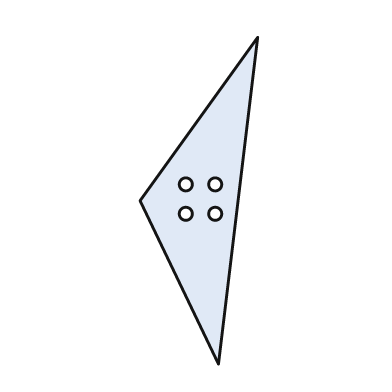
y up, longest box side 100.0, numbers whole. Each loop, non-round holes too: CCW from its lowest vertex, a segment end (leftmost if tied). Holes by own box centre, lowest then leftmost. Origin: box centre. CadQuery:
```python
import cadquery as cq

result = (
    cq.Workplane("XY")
    .moveTo(6.0, -50.0)
    .lineTo(18.0, 50.0)
    .lineTo(-18.0, 0.0)
    .close()
    .moveTo(-4.0, -4.0)
    .circle(2.0)
    .moveTo(5.0, -4.0)
    .circle(2.0)
    .moveTo(-4.0, 5.0)
    .circle(2.0)
    .moveTo(5.0, 5.0)
    .circle(2.0)
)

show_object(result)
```